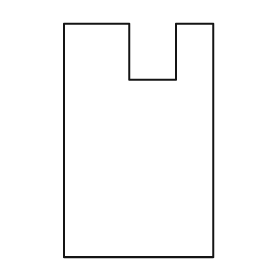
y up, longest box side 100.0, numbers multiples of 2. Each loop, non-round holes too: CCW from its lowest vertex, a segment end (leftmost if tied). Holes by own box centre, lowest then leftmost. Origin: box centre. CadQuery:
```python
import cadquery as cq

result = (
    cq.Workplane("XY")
    .moveTo(-32.0, -50.0)
    .lineTo(32.0, -50.0)
    .lineTo(32.0, 50.0)
    .lineTo(16.0, 50.0)
    .lineTo(16.0, 26.0)
    .lineTo(-4.0, 26.0)
    .lineTo(-4.0, 50.0)
    .lineTo(-32.0, 50.0)
    .close()
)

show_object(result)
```